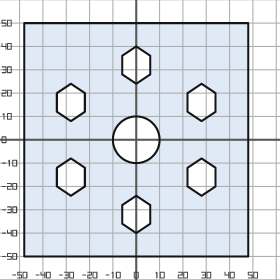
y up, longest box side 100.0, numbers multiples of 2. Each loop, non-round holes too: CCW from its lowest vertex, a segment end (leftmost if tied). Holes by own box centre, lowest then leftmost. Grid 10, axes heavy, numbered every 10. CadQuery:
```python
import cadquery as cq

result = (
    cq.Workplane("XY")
    .moveTo(-48.0, -50.0)
    .lineTo(48.0, -50.0)
    .lineTo(48.0, 50.0)
    .lineTo(-48.0, 50.0)
    .close()
    .moveTo(0.0, -40.0)
    .lineTo(6.0, -36.0)
    .lineTo(6.0, -28.0)
    .lineTo(0.0, -24.0)
    .lineTo(-6.0, -28.0)
    .lineTo(-6.0, -36.0)
    .close()
    .moveTo(-28.0, -24.0)
    .lineTo(-22.0, -20.0)
    .lineTo(-22.0, -12.0)
    .lineTo(-28.0, -8.0)
    .lineTo(-34.0, -12.0)
    .lineTo(-34.0, -20.0)
    .close()
    .moveTo(28.0, -24.0)
    .lineTo(34.0, -20.0)
    .lineTo(34.0, -12.0)
    .lineTo(28.0, -8.0)
    .lineTo(22.0, -12.0)
    .lineTo(22.0, -20.0)
    .close()
    .moveTo(0.0, 0.0)
    .circle(10.0)
    .moveTo(-28.0, 8.0)
    .lineTo(-22.0, 12.0)
    .lineTo(-22.0, 20.0)
    .lineTo(-28.0, 24.0)
    .lineTo(-34.0, 20.0)
    .lineTo(-34.0, 12.0)
    .close()
    .moveTo(28.0, 8.0)
    .lineTo(34.0, 12.0)
    .lineTo(34.0, 20.0)
    .lineTo(28.0, 24.0)
    .lineTo(22.0, 20.0)
    .lineTo(22.0, 12.0)
    .close()
    .moveTo(0.0, 24.0)
    .lineTo(6.0, 28.0)
    .lineTo(6.0, 36.0)
    .lineTo(0.0, 40.0)
    .lineTo(-6.0, 36.0)
    .lineTo(-6.0, 28.0)
    .close()
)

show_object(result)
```